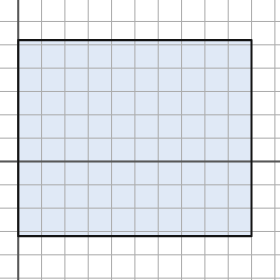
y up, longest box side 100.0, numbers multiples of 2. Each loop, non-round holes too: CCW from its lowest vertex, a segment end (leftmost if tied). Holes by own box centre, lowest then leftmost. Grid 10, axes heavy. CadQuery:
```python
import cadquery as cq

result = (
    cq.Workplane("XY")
    .moveTo(0.0, -32.0)
    .lineTo(100.0, -32.0)
    .lineTo(100.0, 52.0)
    .lineTo(0.0, 52.0)
    .close()
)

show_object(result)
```